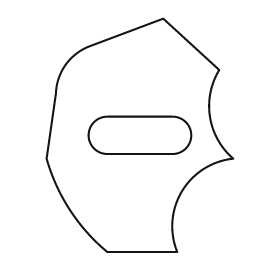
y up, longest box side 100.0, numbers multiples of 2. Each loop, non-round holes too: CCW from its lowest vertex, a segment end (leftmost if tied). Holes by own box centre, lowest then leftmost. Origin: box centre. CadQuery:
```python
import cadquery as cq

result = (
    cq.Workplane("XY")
    .moveTo(-14.0, -50.0)
    .lineTo(16.0, -50.0)
    .threePointArc((18.0, -24.0), (40.0, -10.0))
    .threePointArc((30.0, 8.0), (34.0, 28.0))
    .lineTo(10.0, 50.0)
    .lineTo(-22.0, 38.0)
    .threePointArc((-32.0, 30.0), (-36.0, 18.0))
    .lineTo(-40.0, -10.0)
    .threePointArc((-30.0, -32.0), (-14.0, -50.0))
    .close()
    .moveTo(-14.0, -8.0)
    .lineTo(14.0, -8.0)
    .threePointArc((22.0, 0.0), (14.0, 8.0))
    .lineTo(-14.0, 8.0)
    .threePointArc((-22.0, 0.0), (-14.0, -8.0))
    .close()
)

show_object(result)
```